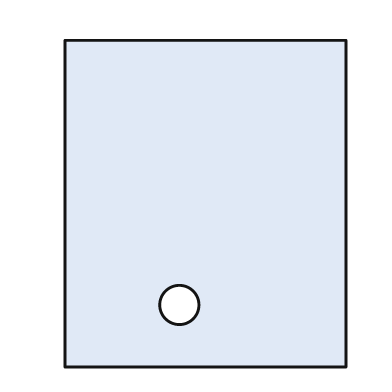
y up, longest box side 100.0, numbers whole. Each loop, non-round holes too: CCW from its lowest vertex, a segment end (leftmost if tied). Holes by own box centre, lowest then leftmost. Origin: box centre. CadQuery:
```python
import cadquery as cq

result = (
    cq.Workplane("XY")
    .moveTo(-43.0, -50.0)
    .lineTo(43.0, -50.0)
    .lineTo(43.0, 50.0)
    .lineTo(-43.0, 50.0)
    .close()
    .moveTo(-8.0, -31.0)
    .circle(6.0)
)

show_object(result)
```